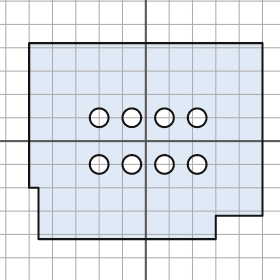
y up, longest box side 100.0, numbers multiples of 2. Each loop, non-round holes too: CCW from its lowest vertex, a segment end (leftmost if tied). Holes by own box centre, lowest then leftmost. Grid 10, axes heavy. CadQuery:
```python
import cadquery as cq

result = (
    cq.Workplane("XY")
    .moveTo(-46.0, -42.0)
    .lineTo(30.0, -42.0)
    .lineTo(30.0, -32.0)
    .lineTo(50.0, -32.0)
    .lineTo(50.0, 42.0)
    .lineTo(-50.0, 42.0)
    .lineTo(-50.0, -20.0)
    .lineTo(-46.0, -20.0)
    .close()
    .moveTo(-20.0, -10.0)
    .circle(4.0)
    .moveTo(-6.0, -10.0)
    .circle(4.0)
    .moveTo(8.0, -10.0)
    .circle(4.0)
    .moveTo(22.0, -10.0)
    .circle(4.0)
    .moveTo(-20.0, 10.0)
    .circle(4.0)
    .moveTo(-6.0, 10.0)
    .circle(4.0)
    .moveTo(8.0, 10.0)
    .circle(4.0)
    .moveTo(22.0, 10.0)
    .circle(4.0)
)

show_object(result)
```